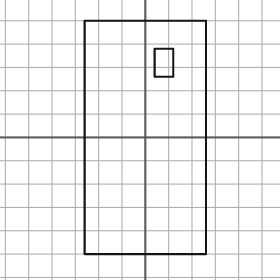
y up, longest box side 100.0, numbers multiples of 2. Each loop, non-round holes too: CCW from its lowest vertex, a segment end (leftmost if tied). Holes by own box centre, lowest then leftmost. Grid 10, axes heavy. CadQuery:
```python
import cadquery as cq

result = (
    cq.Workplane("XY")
    .moveTo(-26.0, -50.0)
    .lineTo(26.0, -50.0)
    .lineTo(26.0, 50.0)
    .lineTo(-26.0, 50.0)
    .close()
    .moveTo(4.0, 26.0)
    .lineTo(12.0, 26.0)
    .lineTo(12.0, 38.0)
    .lineTo(4.0, 38.0)
    .close()
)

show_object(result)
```